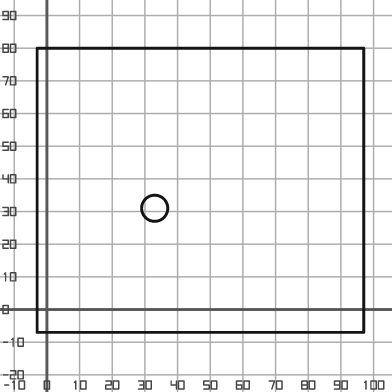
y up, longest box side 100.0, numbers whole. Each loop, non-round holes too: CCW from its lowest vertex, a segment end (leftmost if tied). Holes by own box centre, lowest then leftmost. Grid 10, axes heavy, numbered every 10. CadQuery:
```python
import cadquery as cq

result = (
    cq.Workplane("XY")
    .moveTo(-3.0, -7.0)
    .lineTo(97.0, -7.0)
    .lineTo(97.0, 80.0)
    .lineTo(-3.0, 80.0)
    .close()
    .moveTo(33.0, 31.0)
    .circle(4.0)
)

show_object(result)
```